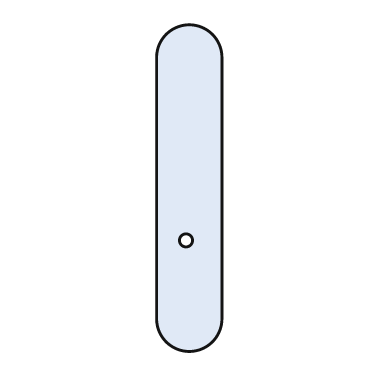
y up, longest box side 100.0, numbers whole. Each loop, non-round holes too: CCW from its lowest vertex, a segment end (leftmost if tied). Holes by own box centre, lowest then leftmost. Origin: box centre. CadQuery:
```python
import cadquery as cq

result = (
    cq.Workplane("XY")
    .moveTo(-10.0, -40.0)
    .threePointArc((0.0, -50.0), (10.0, -40.0))
    .lineTo(10.0, 40.0)
    .threePointArc((0.0, 50.0), (-10.0, 40.0))
    .close()
    .moveTo(-1.0, -16.0)
    .circle(2.0)
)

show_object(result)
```